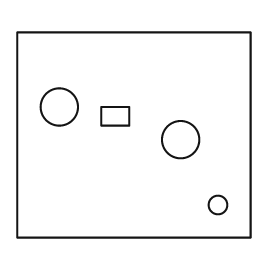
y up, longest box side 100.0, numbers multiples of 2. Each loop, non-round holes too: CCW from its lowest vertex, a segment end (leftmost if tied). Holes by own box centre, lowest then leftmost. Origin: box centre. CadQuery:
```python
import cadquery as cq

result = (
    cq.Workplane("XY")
    .moveTo(-50.0, -44.0)
    .lineTo(50.0, -44.0)
    .lineTo(50.0, 44.0)
    .lineTo(-50.0, 44.0)
    .close()
    .moveTo(36.0, -30.0)
    .circle(4.0)
    .moveTo(20.0, -2.0)
    .circle(8.0)
    .moveTo(-14.0, 4.0)
    .lineTo(-2.0, 4.0)
    .lineTo(-2.0, 12.0)
    .lineTo(-14.0, 12.0)
    .close()
    .moveTo(-32.0, 12.0)
    .circle(8.0)
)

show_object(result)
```